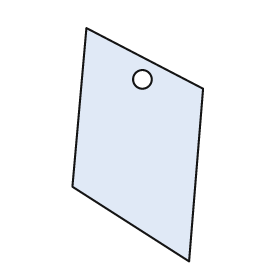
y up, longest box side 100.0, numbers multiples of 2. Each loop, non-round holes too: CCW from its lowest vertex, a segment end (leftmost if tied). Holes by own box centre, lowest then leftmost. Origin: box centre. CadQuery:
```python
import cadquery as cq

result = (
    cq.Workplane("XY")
    .moveTo(22.0, -50.0)
    .lineTo(28.0, 24.0)
    .lineTo(-22.0, 50.0)
    .lineTo(-28.0, -18.0)
    .close()
    .moveTo(2.0, 28.0)
    .circle(4.0)
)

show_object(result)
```